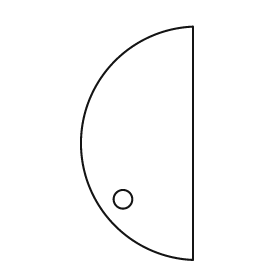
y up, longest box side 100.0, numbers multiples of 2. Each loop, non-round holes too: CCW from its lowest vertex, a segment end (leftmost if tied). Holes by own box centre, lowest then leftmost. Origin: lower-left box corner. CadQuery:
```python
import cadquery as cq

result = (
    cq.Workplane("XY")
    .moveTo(48.0, 0.0)
    .lineTo(48.0, 100.0)
    .threePointArc((0.0, 50.0), (48.0, 0.0))
    .close()
    .moveTo(18.0, 26.0)
    .circle(4.0)
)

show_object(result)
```